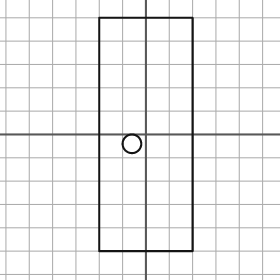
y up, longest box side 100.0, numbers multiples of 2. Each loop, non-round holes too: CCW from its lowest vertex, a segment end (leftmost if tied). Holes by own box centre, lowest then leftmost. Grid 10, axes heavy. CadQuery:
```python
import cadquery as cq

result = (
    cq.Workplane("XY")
    .moveTo(-20.0, -50.0)
    .lineTo(20.0, -50.0)
    .lineTo(20.0, 50.0)
    .lineTo(-20.0, 50.0)
    .close()
    .moveTo(-6.0, -4.0)
    .circle(4.0)
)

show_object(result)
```